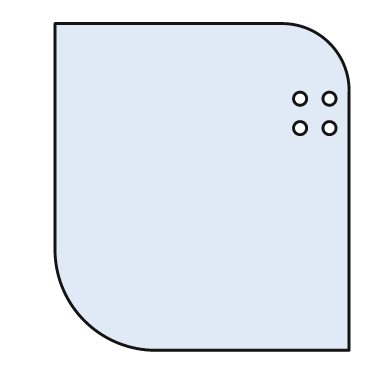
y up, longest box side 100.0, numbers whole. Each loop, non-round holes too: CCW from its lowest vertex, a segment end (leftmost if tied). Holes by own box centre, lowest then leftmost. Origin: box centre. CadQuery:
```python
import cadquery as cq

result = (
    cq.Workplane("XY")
    .moveTo(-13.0, -50.0)
    .lineTo(45.0, -50.0)
    .lineTo(45.0, 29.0)
    .threePointArc((39.0, 44.0), (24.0, 50.0))
    .lineTo(-45.0, 50.0)
    .lineTo(-45.0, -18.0)
    .threePointArc((-36.0, -41.0), (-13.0, -50.0))
    .close()
    .moveTo(30.0, 18.0)
    .circle(2.0)
    .moveTo(39.0, 18.0)
    .circle(2.0)
    .moveTo(30.0, 27.0)
    .circle(2.0)
    .moveTo(39.0, 27.0)
    .circle(2.0)
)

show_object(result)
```